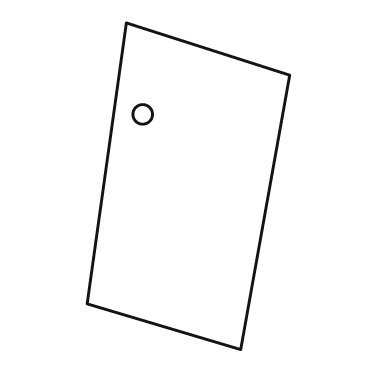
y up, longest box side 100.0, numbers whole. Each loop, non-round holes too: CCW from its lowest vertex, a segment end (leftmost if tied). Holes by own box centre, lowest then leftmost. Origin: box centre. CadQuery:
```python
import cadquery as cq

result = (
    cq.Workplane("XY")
    .moveTo(16.0, -50.0)
    .lineTo(31.0, 34.0)
    .lineTo(-19.0, 50.0)
    .lineTo(-31.0, -36.0)
    .close()
    .moveTo(-14.0, 22.0)
    .circle(3.0)
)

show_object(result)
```